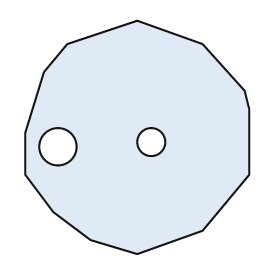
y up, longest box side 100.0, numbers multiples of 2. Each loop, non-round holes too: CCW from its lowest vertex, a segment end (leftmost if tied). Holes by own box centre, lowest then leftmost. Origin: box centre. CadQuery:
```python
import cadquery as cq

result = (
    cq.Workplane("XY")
    .moveTo(0.0, -50.0)
    .lineTo(28.0, -40.0)
    .lineTo(48.0, -16.0)
    .lineTo(48.0, 12.0)
    .lineTo(46.0, 20.0)
    .lineTo(28.0, 40.0)
    .lineTo(0.0, 50.0)
    .lineTo(-30.0, 40.0)
    .lineTo(-40.0, 28.0)
    .lineTo(-48.0, 2.0)
    .lineTo(-48.0, -16.0)
    .lineTo(-36.0, -32.0)
    .lineTo(-20.0, -44.0)
    .close()
    .moveTo(-34.0, -4.0)
    .circle(8.0)
    .moveTo(6.0, -2.0)
    .circle(6.0)
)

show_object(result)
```